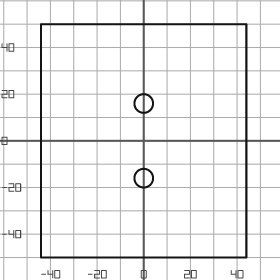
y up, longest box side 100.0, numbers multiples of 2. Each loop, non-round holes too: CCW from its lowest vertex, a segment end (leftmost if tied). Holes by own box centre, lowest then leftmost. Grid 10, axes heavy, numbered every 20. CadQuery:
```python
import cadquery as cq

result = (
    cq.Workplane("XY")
    .moveTo(-44.0, -50.0)
    .lineTo(44.0, -50.0)
    .lineTo(44.0, 50.0)
    .lineTo(-44.0, 50.0)
    .close()
    .moveTo(0.0, -16.0)
    .circle(4.0)
    .moveTo(0.0, 16.0)
    .circle(4.0)
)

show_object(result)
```